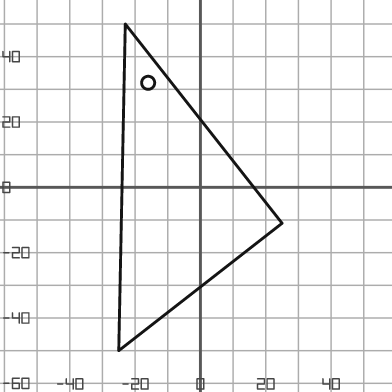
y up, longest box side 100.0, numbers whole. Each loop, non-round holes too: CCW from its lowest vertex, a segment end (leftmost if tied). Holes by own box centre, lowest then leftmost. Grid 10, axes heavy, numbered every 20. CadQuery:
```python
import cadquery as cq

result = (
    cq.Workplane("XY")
    .moveTo(-25.0, -50.0)
    .lineTo(25.0, -11.0)
    .lineTo(-23.0, 50.0)
    .close()
    .moveTo(-16.0, 32.0)
    .circle(2.0)
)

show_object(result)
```